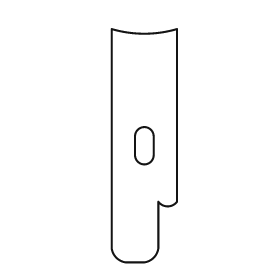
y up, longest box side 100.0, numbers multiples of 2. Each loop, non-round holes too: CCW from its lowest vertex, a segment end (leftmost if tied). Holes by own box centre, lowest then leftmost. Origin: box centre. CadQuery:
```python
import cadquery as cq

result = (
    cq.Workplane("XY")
    .moveTo(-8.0, -50.0)
    .lineTo(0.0, -50.0)
    .threePointArc((4.0, -48.0), (6.0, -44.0))
    .lineTo(6.0, -24.0)
    .threePointArc((10.0, -26.0), (14.0, -24.0))
    .lineTo(14.0, 50.0)
    .threePointArc((0.0, 48.0), (-14.0, 50.0))
    .lineTo(-14.0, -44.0)
    .threePointArc((-12.0, -48.0), (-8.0, -50.0))
    .close()
    .moveTo(-4.0, -4.0)
    .threePointArc((0.0, -8.0), (4.0, -4.0))
    .lineTo(4.0, 4.0)
    .threePointArc((0.0, 8.0), (-4.0, 4.0))
    .close()
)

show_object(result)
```